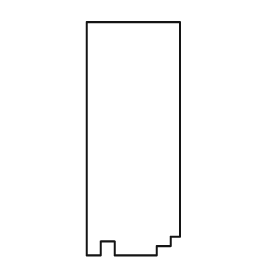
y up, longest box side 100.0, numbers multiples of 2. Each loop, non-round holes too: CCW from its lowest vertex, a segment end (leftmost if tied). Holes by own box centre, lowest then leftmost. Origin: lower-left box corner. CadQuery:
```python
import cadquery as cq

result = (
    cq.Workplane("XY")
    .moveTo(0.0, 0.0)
    .lineTo(6.0, 0.0)
    .lineTo(6.0, 6.0)
    .lineTo(12.0, 6.0)
    .lineTo(12.0, 0.0)
    .lineTo(30.0, 0.0)
    .lineTo(30.0, 4.0)
    .lineTo(36.0, 4.0)
    .lineTo(36.0, 8.0)
    .lineTo(40.0, 8.0)
    .lineTo(40.0, 100.0)
    .lineTo(0.0, 100.0)
    .close()
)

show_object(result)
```